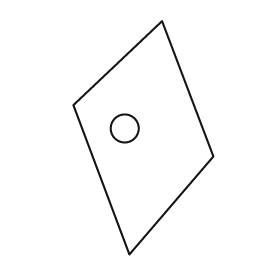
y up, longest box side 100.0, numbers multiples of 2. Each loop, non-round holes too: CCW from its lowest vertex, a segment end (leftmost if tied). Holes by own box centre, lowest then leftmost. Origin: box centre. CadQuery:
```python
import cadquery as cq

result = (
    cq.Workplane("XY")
    .moveTo(-6.0, -50.0)
    .lineTo(30.0, -8.0)
    .lineTo(8.0, 50.0)
    .lineTo(-30.0, 14.0)
    .close()
    .moveTo(-8.0, 4.0)
    .circle(6.0)
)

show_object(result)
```